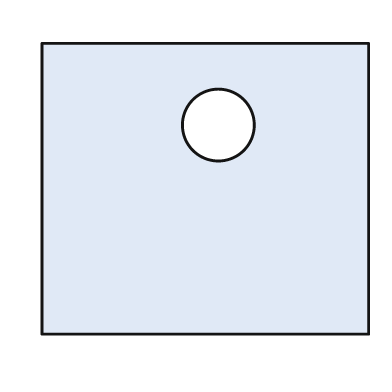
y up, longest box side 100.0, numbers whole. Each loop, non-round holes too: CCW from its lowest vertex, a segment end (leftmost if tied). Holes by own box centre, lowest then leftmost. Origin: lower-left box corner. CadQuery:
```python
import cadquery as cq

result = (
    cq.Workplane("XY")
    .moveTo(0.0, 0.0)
    .lineTo(100.0, 0.0)
    .lineTo(100.0, 89.0)
    .lineTo(0.0, 89.0)
    .close()
    .moveTo(54.0, 64.0)
    .circle(11.0)
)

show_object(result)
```